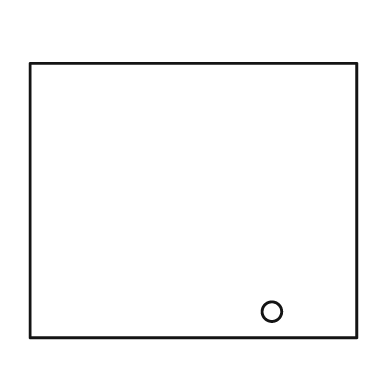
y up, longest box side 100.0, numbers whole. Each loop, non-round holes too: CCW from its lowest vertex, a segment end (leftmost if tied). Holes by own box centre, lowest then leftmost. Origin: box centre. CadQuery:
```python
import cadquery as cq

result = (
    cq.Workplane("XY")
    .moveTo(-50.0, -42.0)
    .lineTo(50.0, -42.0)
    .lineTo(50.0, 42.0)
    .lineTo(-50.0, 42.0)
    .close()
    .moveTo(24.0, -34.0)
    .circle(3.0)
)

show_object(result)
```